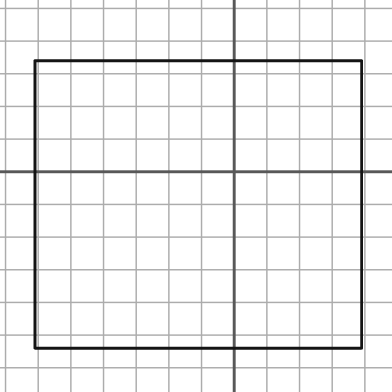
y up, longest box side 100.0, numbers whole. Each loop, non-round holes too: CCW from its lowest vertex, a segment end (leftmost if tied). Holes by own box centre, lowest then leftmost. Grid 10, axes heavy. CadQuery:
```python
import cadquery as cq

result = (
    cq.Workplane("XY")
    .moveTo(-61.0, -54.0)
    .lineTo(39.0, -54.0)
    .lineTo(39.0, 34.0)
    .lineTo(-61.0, 34.0)
    .close()
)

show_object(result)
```